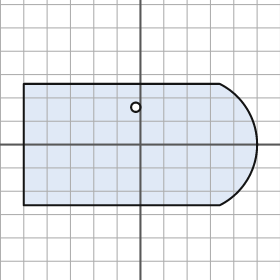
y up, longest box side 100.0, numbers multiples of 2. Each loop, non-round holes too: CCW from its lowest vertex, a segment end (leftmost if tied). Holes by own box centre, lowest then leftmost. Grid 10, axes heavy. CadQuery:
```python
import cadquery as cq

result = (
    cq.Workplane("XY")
    .moveTo(-50.0, -26.0)
    .lineTo(34.0, -26.0)
    .threePointArc((50.0, 0.0), (34.0, 26.0))
    .lineTo(-50.0, 26.0)
    .close()
    .moveTo(-2.0, 16.0)
    .circle(2.0)
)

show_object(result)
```